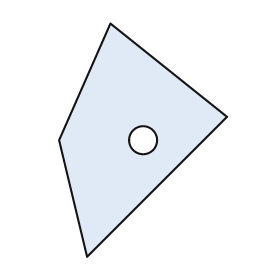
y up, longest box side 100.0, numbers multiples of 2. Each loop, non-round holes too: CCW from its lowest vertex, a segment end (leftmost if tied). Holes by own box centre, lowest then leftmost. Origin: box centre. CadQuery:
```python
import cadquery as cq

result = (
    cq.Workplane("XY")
    .moveTo(-24.0, -50.0)
    .lineTo(36.0, 10.0)
    .lineTo(-14.0, 50.0)
    .lineTo(-36.0, 0.0)
    .close()
    .moveTo(0.0, 0.0)
    .circle(6.0)
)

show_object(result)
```